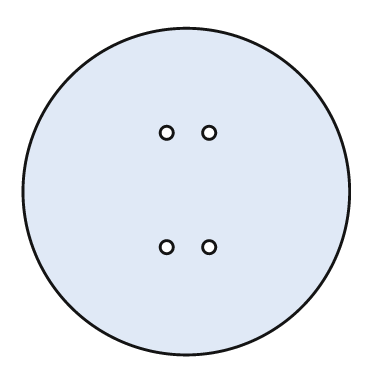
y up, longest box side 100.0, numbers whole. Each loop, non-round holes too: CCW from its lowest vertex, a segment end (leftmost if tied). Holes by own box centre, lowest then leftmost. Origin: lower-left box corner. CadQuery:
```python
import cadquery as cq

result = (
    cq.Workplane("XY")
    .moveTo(50.0, 50.0)
    .circle(50.0)
    .moveTo(44.0, 33.0)
    .circle(2.0)
    .moveTo(57.0, 33.0)
    .circle(2.0)
    .moveTo(44.0, 68.0)
    .circle(2.0)
    .moveTo(57.0, 68.0)
    .circle(2.0)
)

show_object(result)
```